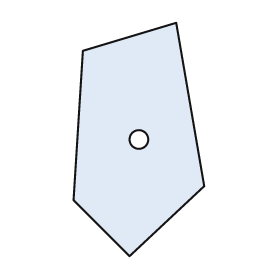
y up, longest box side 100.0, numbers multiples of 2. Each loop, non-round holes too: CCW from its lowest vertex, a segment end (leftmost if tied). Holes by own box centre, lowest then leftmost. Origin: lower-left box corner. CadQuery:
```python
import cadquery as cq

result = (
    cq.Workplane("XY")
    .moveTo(24.0, 0.0)
    .lineTo(56.0, 30.0)
    .lineTo(44.0, 100.0)
    .lineTo(4.0, 88.0)
    .lineTo(0.0, 24.0)
    .close()
    .moveTo(28.0, 50.0)
    .circle(4.0)
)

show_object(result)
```